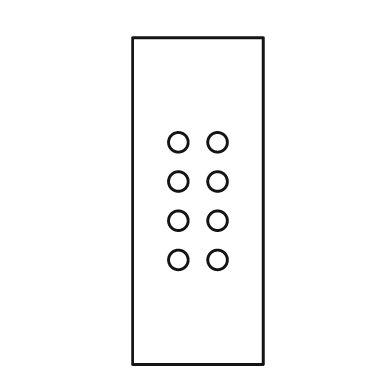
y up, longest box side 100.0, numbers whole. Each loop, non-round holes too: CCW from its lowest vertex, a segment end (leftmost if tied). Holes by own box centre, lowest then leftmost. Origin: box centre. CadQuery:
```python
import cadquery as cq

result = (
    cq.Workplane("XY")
    .moveTo(-20.0, -50.0)
    .lineTo(20.0, -50.0)
    .lineTo(20.0, 50.0)
    .lineTo(-20.0, 50.0)
    .close()
    .moveTo(-6.0, -18.0)
    .circle(3.0)
    .moveTo(6.0, -18.0)
    .circle(3.0)
    .moveTo(-6.0, -6.0)
    .circle(3.0)
    .moveTo(6.0, -6.0)
    .circle(3.0)
    .moveTo(-6.0, 6.0)
    .circle(3.0)
    .moveTo(6.0, 6.0)
    .circle(3.0)
    .moveTo(-6.0, 18.0)
    .circle(3.0)
    .moveTo(6.0, 18.0)
    .circle(3.0)
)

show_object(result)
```